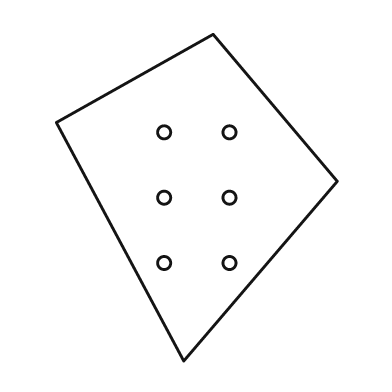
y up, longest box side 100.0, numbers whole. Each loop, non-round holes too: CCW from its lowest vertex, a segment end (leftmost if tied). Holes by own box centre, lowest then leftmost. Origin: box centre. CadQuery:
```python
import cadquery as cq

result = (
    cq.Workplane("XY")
    .moveTo(-4.0, -50.0)
    .lineTo(43.0, 5.0)
    .lineTo(5.0, 50.0)
    .lineTo(-43.0, 23.0)
    .close()
    .moveTo(-10.0, -20.0)
    .circle(2.0)
    .moveTo(10.0, -20.0)
    .circle(2.0)
    .moveTo(-10.0, 0.0)
    .circle(2.0)
    .moveTo(10.0, 0.0)
    .circle(2.0)
    .moveTo(-10.0, 20.0)
    .circle(2.0)
    .moveTo(10.0, 20.0)
    .circle(2.0)
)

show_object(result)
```